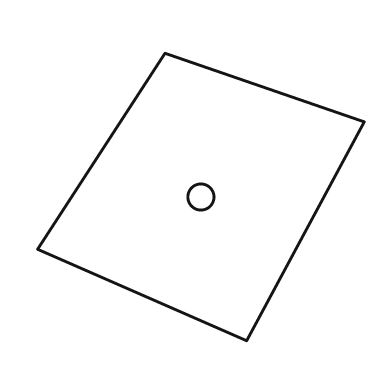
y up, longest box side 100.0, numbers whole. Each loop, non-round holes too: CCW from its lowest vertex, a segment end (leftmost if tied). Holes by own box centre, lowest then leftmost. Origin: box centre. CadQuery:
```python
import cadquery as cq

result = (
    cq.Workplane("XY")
    .moveTo(14.0, -44.0)
    .lineTo(50.0, 23.0)
    .lineTo(-11.0, 44.0)
    .lineTo(-50.0, -16.0)
    .close()
    .moveTo(0.0, 0.0)
    .circle(4.0)
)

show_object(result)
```